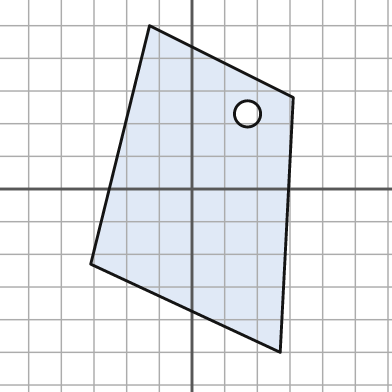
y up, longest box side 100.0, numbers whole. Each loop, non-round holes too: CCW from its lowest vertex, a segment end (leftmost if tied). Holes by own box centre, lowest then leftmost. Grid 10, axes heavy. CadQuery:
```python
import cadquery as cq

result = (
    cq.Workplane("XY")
    .moveTo(27.0, -50.0)
    .lineTo(31.0, 28.0)
    .lineTo(-13.0, 50.0)
    .lineTo(-31.0, -23.0)
    .close()
    .moveTo(17.0, 23.0)
    .circle(4.0)
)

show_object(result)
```